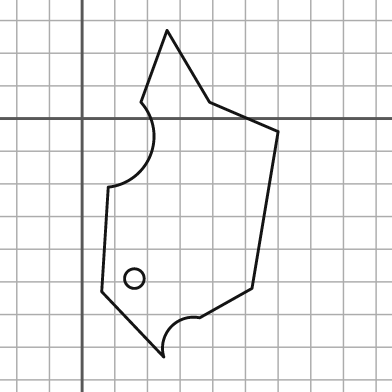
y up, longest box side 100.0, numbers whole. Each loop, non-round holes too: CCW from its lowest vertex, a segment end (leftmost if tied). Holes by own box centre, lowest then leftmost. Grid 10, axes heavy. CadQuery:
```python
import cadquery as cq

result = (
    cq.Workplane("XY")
    .moveTo(25.0, -73.0)
    .threePointArc((27.0, -64.0), (36.0, -61.0))
    .lineTo(52.0, -52.0)
    .lineTo(60.0, -4.0)
    .lineTo(39.0, 5.0)
    .lineTo(26.0, 27.0)
    .lineTo(18.0, 5.0)
    .threePointArc((21.0, -11.0), (8.0, -21.0))
    .lineTo(6.0, -53.0)
    .close()
    .moveTo(16.0, -49.0)
    .circle(3.0)
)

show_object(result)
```